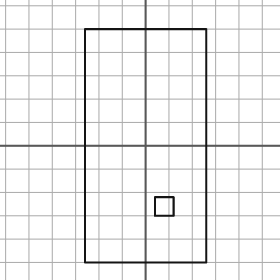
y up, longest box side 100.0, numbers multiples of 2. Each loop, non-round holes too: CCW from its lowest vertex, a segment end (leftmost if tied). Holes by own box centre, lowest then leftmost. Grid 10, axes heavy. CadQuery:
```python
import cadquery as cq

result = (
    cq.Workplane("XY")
    .moveTo(-26.0, -50.0)
    .lineTo(26.0, -50.0)
    .lineTo(26.0, 50.0)
    .lineTo(-26.0, 50.0)
    .close()
    .moveTo(4.0, -30.0)
    .lineTo(12.0, -30.0)
    .lineTo(12.0, -22.0)
    .lineTo(4.0, -22.0)
    .close()
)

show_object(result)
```